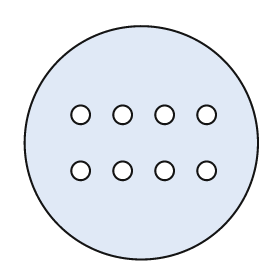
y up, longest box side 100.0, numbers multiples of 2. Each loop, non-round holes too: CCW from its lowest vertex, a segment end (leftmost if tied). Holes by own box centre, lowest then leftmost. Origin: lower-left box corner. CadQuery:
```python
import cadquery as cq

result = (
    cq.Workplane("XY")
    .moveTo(50.0, 50.0)
    .circle(50.0)
    .moveTo(24.0, 38.0)
    .circle(4.0)
    .moveTo(42.0, 38.0)
    .circle(4.0)
    .moveTo(60.0, 38.0)
    .circle(4.0)
    .moveTo(78.0, 38.0)
    .circle(4.0)
    .moveTo(24.0, 62.0)
    .circle(4.0)
    .moveTo(42.0, 62.0)
    .circle(4.0)
    .moveTo(60.0, 62.0)
    .circle(4.0)
    .moveTo(78.0, 62.0)
    .circle(4.0)
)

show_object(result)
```